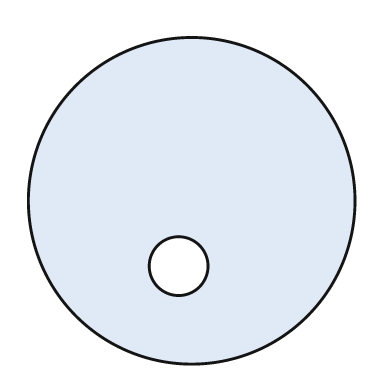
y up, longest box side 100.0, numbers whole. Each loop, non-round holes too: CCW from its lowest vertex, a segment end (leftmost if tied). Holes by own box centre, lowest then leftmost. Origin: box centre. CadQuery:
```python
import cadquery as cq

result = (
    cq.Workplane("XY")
    .moveTo(0.0, 0.0)
    .circle(50.0)
    .moveTo(-4.0, -20.0)
    .circle(9.0)
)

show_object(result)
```